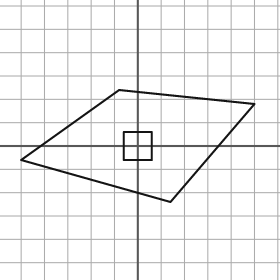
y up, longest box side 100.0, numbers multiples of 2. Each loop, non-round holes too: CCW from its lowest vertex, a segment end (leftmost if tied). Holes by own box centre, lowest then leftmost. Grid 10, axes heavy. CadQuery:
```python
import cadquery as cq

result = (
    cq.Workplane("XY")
    .moveTo(14.0, -24.0)
    .lineTo(50.0, 18.0)
    .lineTo(-8.0, 24.0)
    .lineTo(-50.0, -6.0)
    .close()
    .moveTo(-6.0, -6.0)
    .lineTo(6.0, -6.0)
    .lineTo(6.0, 6.0)
    .lineTo(-6.0, 6.0)
    .close()
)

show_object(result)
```